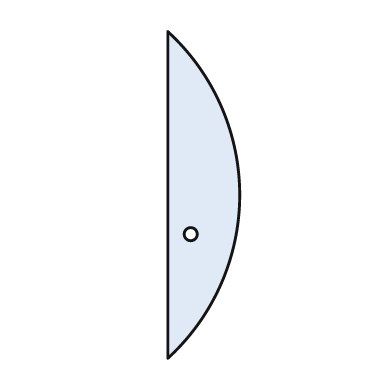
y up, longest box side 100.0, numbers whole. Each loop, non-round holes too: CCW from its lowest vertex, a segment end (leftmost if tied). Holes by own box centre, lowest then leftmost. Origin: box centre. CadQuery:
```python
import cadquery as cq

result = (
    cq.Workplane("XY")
    .moveTo(-11.0, -50.0)
    .threePointArc((11.0, 0.0), (-11.0, 50.0))
    .close()
    .moveTo(-4.0, -12.0)
    .circle(2.0)
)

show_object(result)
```